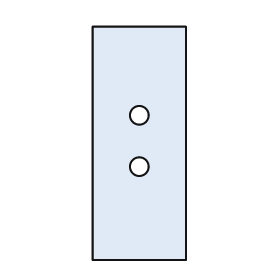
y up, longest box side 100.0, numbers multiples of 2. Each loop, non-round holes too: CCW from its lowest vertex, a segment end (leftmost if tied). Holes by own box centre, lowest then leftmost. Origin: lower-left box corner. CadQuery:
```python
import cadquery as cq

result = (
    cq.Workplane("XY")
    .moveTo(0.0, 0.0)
    .lineTo(40.0, 0.0)
    .lineTo(40.0, 100.0)
    .lineTo(0.0, 100.0)
    .close()
    .moveTo(20.0, 40.0)
    .circle(4.0)
    .moveTo(20.0, 62.0)
    .circle(4.0)
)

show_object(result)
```